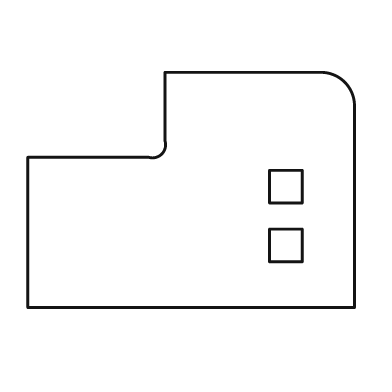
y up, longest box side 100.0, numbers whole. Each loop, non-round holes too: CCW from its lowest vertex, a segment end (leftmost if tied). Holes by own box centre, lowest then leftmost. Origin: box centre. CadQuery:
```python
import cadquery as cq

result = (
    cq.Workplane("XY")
    .moveTo(-50.0, -36.0)
    .lineTo(50.0, -36.0)
    .lineTo(50.0, 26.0)
    .threePointArc((47.0, 33.0), (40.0, 36.0))
    .lineTo(-8.0, 36.0)
    .lineTo(-8.0, 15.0)
    .threePointArc((-9.0, 11.0), (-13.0, 10.0))
    .lineTo(-50.0, 10.0)
    .close()
    .moveTo(24.0, -22.0)
    .lineTo(34.0, -22.0)
    .lineTo(34.0, -12.0)
    .lineTo(24.0, -12.0)
    .close()
    .moveTo(24.0, -4.0)
    .lineTo(34.0, -4.0)
    .lineTo(34.0, 6.0)
    .lineTo(24.0, 6.0)
    .close()
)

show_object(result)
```